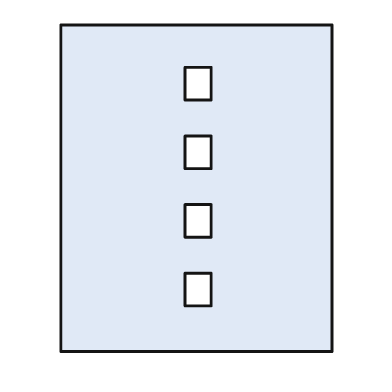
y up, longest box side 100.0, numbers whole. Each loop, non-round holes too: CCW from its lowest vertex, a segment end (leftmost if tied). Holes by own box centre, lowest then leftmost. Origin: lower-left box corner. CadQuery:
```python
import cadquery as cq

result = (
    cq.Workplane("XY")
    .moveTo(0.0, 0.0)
    .lineTo(83.0, 0.0)
    .lineTo(83.0, 100.0)
    .lineTo(0.0, 100.0)
    .close()
    .moveTo(38.0, 14.0)
    .lineTo(46.0, 14.0)
    .lineTo(46.0, 24.0)
    .lineTo(38.0, 24.0)
    .close()
    .moveTo(38.0, 35.0)
    .lineTo(46.0, 35.0)
    .lineTo(46.0, 45.0)
    .lineTo(38.0, 45.0)
    .close()
    .moveTo(38.0, 56.0)
    .lineTo(46.0, 56.0)
    .lineTo(46.0, 66.0)
    .lineTo(38.0, 66.0)
    .close()
    .moveTo(38.0, 77.0)
    .lineTo(46.0, 77.0)
    .lineTo(46.0, 87.0)
    .lineTo(38.0, 87.0)
    .close()
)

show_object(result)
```